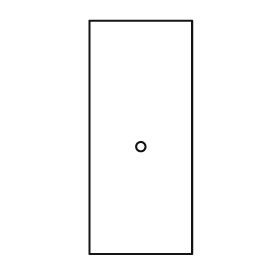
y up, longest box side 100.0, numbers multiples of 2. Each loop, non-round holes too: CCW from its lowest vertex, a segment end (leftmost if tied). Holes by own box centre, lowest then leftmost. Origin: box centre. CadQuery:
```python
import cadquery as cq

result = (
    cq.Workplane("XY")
    .moveTo(-22.0, -50.0)
    .lineTo(22.0, -50.0)
    .lineTo(22.0, 50.0)
    .lineTo(-22.0, 50.0)
    .close()
    .moveTo(0.0, -4.0)
    .circle(2.0)
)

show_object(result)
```